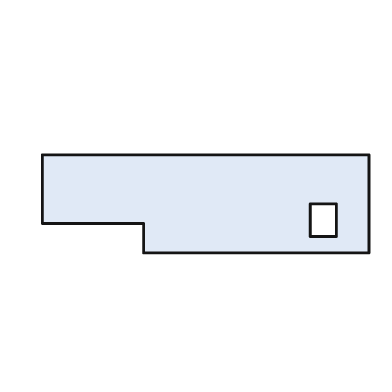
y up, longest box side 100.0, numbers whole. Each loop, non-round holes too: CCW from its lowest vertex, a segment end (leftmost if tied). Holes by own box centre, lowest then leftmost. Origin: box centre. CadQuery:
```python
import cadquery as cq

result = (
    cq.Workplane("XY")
    .moveTo(-19.0, -15.0)
    .lineTo(50.0, -15.0)
    .lineTo(50.0, 15.0)
    .lineTo(-50.0, 15.0)
    .lineTo(-50.0, -6.0)
    .lineTo(-19.0, -6.0)
    .close()
    .moveTo(32.0, -10.0)
    .lineTo(40.0, -10.0)
    .lineTo(40.0, 0.0)
    .lineTo(32.0, 0.0)
    .close()
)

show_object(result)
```